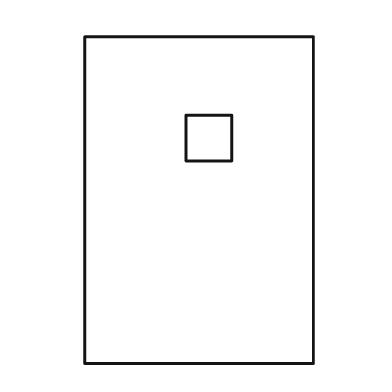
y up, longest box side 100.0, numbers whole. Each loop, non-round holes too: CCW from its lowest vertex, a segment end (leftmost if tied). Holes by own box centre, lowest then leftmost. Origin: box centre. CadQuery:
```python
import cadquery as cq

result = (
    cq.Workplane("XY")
    .moveTo(-35.0, -50.0)
    .lineTo(35.0, -50.0)
    .lineTo(35.0, 50.0)
    .lineTo(-35.0, 50.0)
    .close()
    .moveTo(-4.0, 12.0)
    .lineTo(10.0, 12.0)
    .lineTo(10.0, 26.0)
    .lineTo(-4.0, 26.0)
    .close()
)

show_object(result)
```